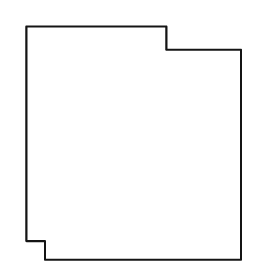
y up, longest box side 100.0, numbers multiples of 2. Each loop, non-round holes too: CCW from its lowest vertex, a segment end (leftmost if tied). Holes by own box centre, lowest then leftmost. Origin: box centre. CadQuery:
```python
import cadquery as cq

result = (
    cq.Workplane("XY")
    .moveTo(-38.0, -50.0)
    .lineTo(46.0, -50.0)
    .lineTo(46.0, 40.0)
    .lineTo(14.0, 40.0)
    .lineTo(14.0, 50.0)
    .lineTo(-46.0, 50.0)
    .lineTo(-46.0, -42.0)
    .lineTo(-38.0, -42.0)
    .close()
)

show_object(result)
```